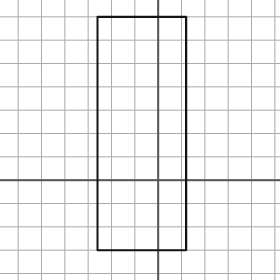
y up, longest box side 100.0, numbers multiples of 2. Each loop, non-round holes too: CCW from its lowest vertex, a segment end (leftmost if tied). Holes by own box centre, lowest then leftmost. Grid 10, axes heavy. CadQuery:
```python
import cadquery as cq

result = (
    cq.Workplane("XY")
    .moveTo(-26.0, -30.0)
    .lineTo(12.0, -30.0)
    .lineTo(12.0, 70.0)
    .lineTo(-26.0, 70.0)
    .close()
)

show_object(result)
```